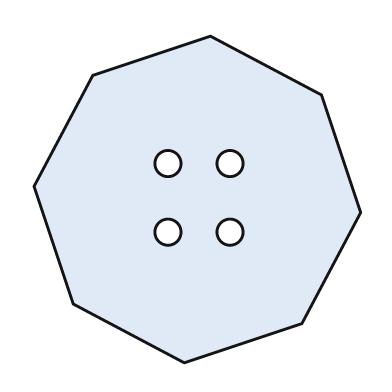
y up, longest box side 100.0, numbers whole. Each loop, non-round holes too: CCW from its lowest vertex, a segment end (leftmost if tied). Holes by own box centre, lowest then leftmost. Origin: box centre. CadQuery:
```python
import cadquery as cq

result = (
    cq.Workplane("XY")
    .moveTo(-4.0, -50.0)
    .lineTo(32.0, -38.0)
    .lineTo(50.0, -4.0)
    .lineTo(38.0, 32.0)
    .lineTo(4.0, 50.0)
    .lineTo(-32.0, 38.0)
    .lineTo(-50.0, 4.0)
    .lineTo(-38.0, -32.0)
    .close()
    .moveTo(-9.0, -10.0)
    .circle(4.0)
    .moveTo(10.0, -10.0)
    .circle(4.0)
    .moveTo(-9.0, 11.0)
    .circle(4.0)
    .moveTo(10.0, 11.0)
    .circle(4.0)
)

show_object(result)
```